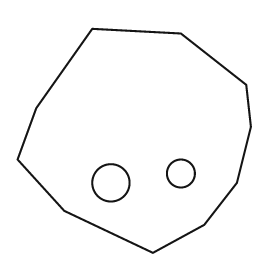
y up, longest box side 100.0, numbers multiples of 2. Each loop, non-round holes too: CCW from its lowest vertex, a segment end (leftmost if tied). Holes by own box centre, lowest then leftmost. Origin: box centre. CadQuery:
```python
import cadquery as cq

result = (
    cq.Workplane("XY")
    .moveTo(8.0, -48.0)
    .lineTo(30.0, -36.0)
    .lineTo(44.0, -18.0)
    .lineTo(50.0, 6.0)
    .lineTo(48.0, 24.0)
    .lineTo(20.0, 46.0)
    .lineTo(-18.0, 48.0)
    .lineTo(-42.0, 14.0)
    .lineTo(-50.0, -8.0)
    .lineTo(-30.0, -30.0)
    .close()
    .moveTo(-10.0, -18.0)
    .circle(8.0)
    .moveTo(20.0, -14.0)
    .circle(6.0)
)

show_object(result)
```